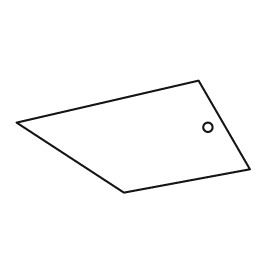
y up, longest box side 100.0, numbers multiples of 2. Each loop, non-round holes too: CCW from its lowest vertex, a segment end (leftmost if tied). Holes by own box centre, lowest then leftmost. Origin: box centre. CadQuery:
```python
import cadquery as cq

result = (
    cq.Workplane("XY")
    .moveTo(-4.0, -24.0)
    .lineTo(50.0, -14.0)
    .lineTo(28.0, 24.0)
    .lineTo(-50.0, 6.0)
    .close()
    .moveTo(32.0, 4.0)
    .circle(2.0)
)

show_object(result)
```